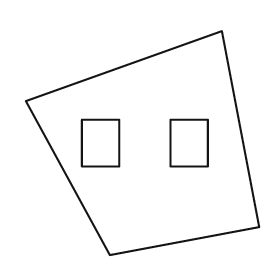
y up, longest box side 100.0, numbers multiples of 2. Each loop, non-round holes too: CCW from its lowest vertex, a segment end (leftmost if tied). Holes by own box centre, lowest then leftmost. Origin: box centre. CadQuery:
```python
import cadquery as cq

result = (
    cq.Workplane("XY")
    .moveTo(-14.0, -48.0)
    .lineTo(50.0, -36.0)
    .lineTo(34.0, 48.0)
    .lineTo(-50.0, 18.0)
    .close()
    .moveTo(-26.0, -10.0)
    .lineTo(-10.0, -10.0)
    .lineTo(-10.0, 10.0)
    .lineTo(-26.0, 10.0)
    .close()
    .moveTo(12.0, -10.0)
    .lineTo(28.0, -10.0)
    .lineTo(28.0, 10.0)
    .lineTo(12.0, 10.0)
    .close()
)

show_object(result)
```